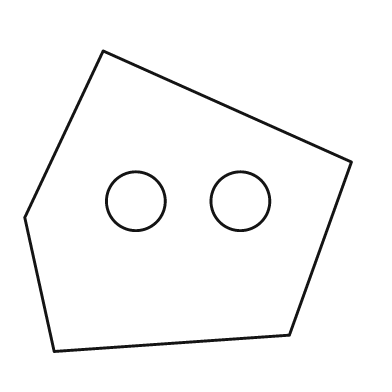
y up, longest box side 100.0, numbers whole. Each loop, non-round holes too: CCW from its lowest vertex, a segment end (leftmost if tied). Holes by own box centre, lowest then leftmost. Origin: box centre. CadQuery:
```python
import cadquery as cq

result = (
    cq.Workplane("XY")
    .moveTo(-41.0, -46.0)
    .lineTo(31.0, -41.0)
    .lineTo(50.0, 12.0)
    .lineTo(-26.0, 46.0)
    .lineTo(-50.0, -5.0)
    .close()
    .moveTo(-16.0, 0.0)
    .circle(9.0)
    .moveTo(16.0, 0.0)
    .circle(9.0)
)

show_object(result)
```